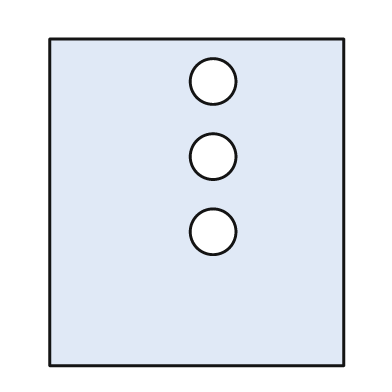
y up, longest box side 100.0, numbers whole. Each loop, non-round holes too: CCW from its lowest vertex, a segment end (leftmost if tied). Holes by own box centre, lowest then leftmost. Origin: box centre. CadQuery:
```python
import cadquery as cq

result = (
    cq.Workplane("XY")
    .moveTo(-45.0, -50.0)
    .lineTo(45.0, -50.0)
    .lineTo(45.0, 50.0)
    .lineTo(-45.0, 50.0)
    .close()
    .moveTo(5.0, -9.0)
    .circle(7.0)
    .moveTo(5.0, 14.0)
    .circle(7.0)
    .moveTo(5.0, 37.0)
    .circle(7.0)
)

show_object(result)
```